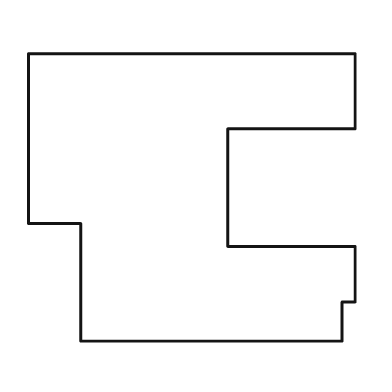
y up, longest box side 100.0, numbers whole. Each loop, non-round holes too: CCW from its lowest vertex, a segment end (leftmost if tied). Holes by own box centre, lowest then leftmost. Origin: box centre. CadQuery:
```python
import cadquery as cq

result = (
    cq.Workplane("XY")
    .moveTo(-34.0, -44.0)
    .lineTo(46.0, -44.0)
    .lineTo(46.0, -32.0)
    .lineTo(50.0, -32.0)
    .lineTo(50.0, -15.0)
    .lineTo(11.0, -15.0)
    .lineTo(11.0, 21.0)
    .lineTo(50.0, 21.0)
    .lineTo(50.0, 44.0)
    .lineTo(-50.0, 44.0)
    .lineTo(-50.0, -8.0)
    .lineTo(-34.0, -8.0)
    .close()
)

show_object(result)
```